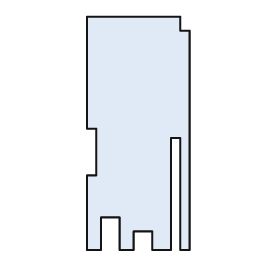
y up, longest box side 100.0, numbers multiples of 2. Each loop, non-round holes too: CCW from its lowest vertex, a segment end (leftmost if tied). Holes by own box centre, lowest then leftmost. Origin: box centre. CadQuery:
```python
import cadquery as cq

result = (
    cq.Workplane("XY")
    .moveTo(-22.0, -50.0)
    .lineTo(-16.0, -50.0)
    .lineTo(-16.0, -36.0)
    .lineTo(-8.0, -36.0)
    .lineTo(-8.0, -50.0)
    .lineTo(-2.0, -50.0)
    .lineTo(-2.0, -42.0)
    .lineTo(6.0, -42.0)
    .lineTo(6.0, -50.0)
    .lineTo(14.0, -50.0)
    .lineTo(14.0, -2.0)
    .lineTo(18.0, -2.0)
    .lineTo(18.0, -50.0)
    .lineTo(22.0, -50.0)
    .lineTo(22.0, 44.0)
    .lineTo(18.0, 44.0)
    .lineTo(18.0, 50.0)
    .lineTo(-22.0, 50.0)
    .lineTo(-22.0, 2.0)
    .lineTo(-18.0, 2.0)
    .lineTo(-18.0, -18.0)
    .lineTo(-22.0, -18.0)
    .close()
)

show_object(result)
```